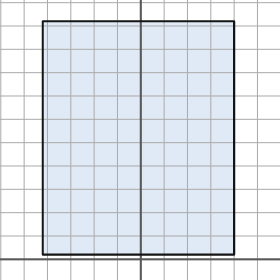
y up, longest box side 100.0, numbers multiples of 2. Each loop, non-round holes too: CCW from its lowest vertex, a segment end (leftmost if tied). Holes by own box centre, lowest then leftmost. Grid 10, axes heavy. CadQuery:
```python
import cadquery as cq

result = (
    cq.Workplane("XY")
    .moveTo(-42.0, 2.0)
    .lineTo(40.0, 2.0)
    .lineTo(40.0, 102.0)
    .lineTo(-42.0, 102.0)
    .close()
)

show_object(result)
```